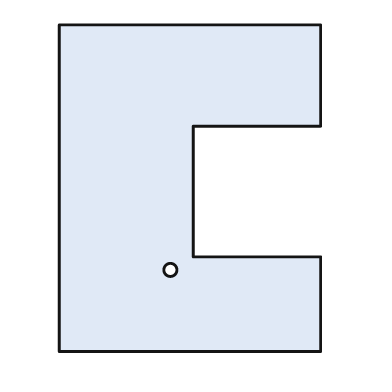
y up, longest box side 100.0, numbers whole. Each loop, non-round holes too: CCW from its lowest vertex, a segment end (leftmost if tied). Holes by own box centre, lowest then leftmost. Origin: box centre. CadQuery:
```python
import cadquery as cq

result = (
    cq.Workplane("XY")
    .moveTo(-40.0, -50.0)
    .lineTo(40.0, -50.0)
    .lineTo(40.0, -21.0)
    .lineTo(1.0, -21.0)
    .lineTo(1.0, 19.0)
    .lineTo(40.0, 19.0)
    .lineTo(40.0, 50.0)
    .lineTo(-40.0, 50.0)
    .close()
    .moveTo(-6.0, -25.0)
    .circle(2.0)
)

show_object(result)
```